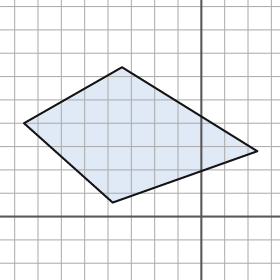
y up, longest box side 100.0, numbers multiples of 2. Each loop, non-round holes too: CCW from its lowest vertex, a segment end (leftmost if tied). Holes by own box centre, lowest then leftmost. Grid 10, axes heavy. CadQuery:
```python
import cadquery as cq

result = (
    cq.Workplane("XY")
    .moveTo(-38.0, 6.0)
    .lineTo(24.0, 28.0)
    .lineTo(-34.0, 64.0)
    .lineTo(-76.0, 40.0)
    .close()
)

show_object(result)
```